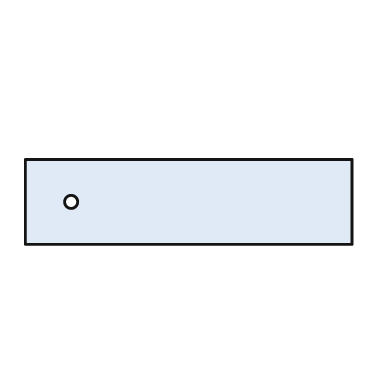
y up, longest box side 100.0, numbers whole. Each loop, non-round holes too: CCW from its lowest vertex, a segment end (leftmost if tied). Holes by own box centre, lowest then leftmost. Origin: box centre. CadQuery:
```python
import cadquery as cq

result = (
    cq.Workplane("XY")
    .moveTo(-50.0, -13.0)
    .lineTo(50.0, -13.0)
    .lineTo(50.0, 13.0)
    .lineTo(-50.0, 13.0)
    .close()
    .moveTo(-36.0, 0.0)
    .circle(2.0)
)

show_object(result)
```